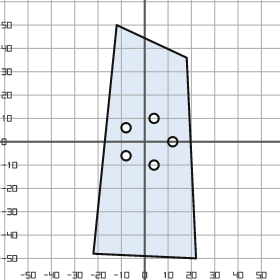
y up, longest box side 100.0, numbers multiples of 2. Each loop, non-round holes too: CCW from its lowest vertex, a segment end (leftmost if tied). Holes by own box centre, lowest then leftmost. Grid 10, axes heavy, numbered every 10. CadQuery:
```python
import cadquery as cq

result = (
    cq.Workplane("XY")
    .moveTo(22.0, -50.0)
    .lineTo(18.0, 36.0)
    .lineTo(-12.0, 50.0)
    .lineTo(-22.0, -48.0)
    .close()
    .moveTo(4.0, -10.0)
    .circle(2.0)
    .moveTo(-8.0, -6.0)
    .circle(2.0)
    .moveTo(12.0, 0.0)
    .circle(2.0)
    .moveTo(-8.0, 6.0)
    .circle(2.0)
    .moveTo(4.0, 10.0)
    .circle(2.0)
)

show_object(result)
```